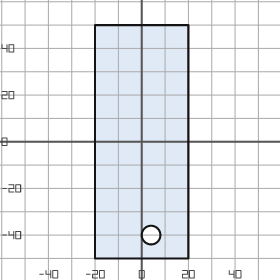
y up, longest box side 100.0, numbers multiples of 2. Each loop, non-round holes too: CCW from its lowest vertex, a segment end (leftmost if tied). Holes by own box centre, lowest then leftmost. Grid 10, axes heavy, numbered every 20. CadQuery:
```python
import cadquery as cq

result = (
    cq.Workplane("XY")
    .moveTo(-20.0, -50.0)
    .lineTo(20.0, -50.0)
    .lineTo(20.0, 50.0)
    .lineTo(-20.0, 50.0)
    .close()
    .moveTo(4.0, -40.0)
    .circle(4.0)
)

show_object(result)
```